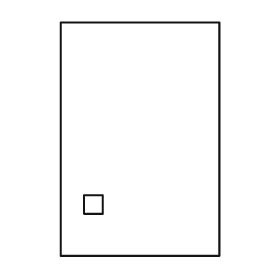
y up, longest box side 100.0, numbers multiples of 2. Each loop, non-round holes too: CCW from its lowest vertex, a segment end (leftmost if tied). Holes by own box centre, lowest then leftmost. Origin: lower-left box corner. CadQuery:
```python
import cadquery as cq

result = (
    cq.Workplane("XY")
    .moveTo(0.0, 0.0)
    .lineTo(68.0, 0.0)
    .lineTo(68.0, 100.0)
    .lineTo(0.0, 100.0)
    .close()
    .moveTo(10.0, 18.0)
    .lineTo(18.0, 18.0)
    .lineTo(18.0, 26.0)
    .lineTo(10.0, 26.0)
    .close()
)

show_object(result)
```